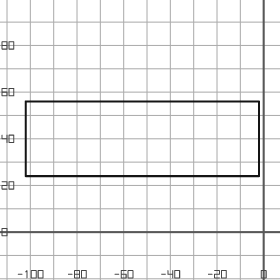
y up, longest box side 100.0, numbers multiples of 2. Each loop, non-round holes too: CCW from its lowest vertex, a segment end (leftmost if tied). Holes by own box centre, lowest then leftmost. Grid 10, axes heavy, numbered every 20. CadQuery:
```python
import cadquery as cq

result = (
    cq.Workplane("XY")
    .moveTo(-102.0, 24.0)
    .lineTo(-2.0, 24.0)
    .lineTo(-2.0, 56.0)
    .lineTo(-102.0, 56.0)
    .close()
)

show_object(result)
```